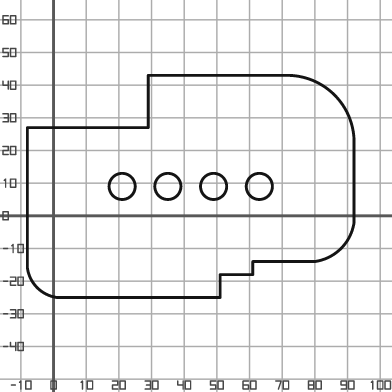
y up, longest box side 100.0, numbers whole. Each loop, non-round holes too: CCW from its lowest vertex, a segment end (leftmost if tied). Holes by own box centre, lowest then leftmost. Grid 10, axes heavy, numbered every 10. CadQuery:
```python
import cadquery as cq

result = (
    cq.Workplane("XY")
    .moveTo(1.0, -25.0)
    .lineTo(51.0, -25.0)
    .lineTo(51.0, -18.0)
    .lineTo(61.0, -18.0)
    .lineTo(61.0, -14.0)
    .lineTo(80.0, -14.0)
    .threePointArc((88.0, -10.0), (92.0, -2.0))
    .lineTo(92.0, 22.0)
    .threePointArc((86.0, 37.0), (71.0, 43.0))
    .lineTo(29.0, 43.0)
    .lineTo(29.0, 27.0)
    .lineTo(-8.0, 27.0)
    .lineTo(-8.0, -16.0)
    .threePointArc((-5.0, -22.0), (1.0, -25.0))
    .close()
    .moveTo(21.0, 9.0)
    .circle(4.0)
    .moveTo(35.0, 9.0)
    .circle(4.0)
    .moveTo(49.0, 9.0)
    .circle(4.0)
    .moveTo(63.0, 9.0)
    .circle(4.0)
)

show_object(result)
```